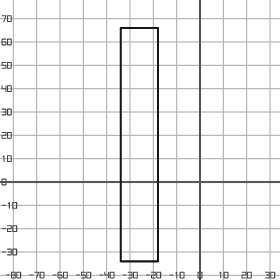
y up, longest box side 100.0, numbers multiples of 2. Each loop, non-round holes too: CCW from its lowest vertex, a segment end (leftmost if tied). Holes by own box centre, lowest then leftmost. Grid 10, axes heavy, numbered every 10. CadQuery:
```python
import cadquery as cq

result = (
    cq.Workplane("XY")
    .moveTo(-34.0, -34.0)
    .lineTo(-18.0, -34.0)
    .lineTo(-18.0, 66.0)
    .lineTo(-34.0, 66.0)
    .close()
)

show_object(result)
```